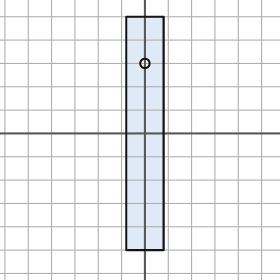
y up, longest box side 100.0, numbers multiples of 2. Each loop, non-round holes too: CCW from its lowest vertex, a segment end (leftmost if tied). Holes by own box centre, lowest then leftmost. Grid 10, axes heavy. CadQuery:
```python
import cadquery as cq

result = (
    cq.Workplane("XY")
    .moveTo(-8.0, -50.0)
    .lineTo(8.0, -50.0)
    .lineTo(8.0, 50.0)
    .lineTo(-8.0, 50.0)
    .close()
    .moveTo(0.0, 30.0)
    .circle(2.0)
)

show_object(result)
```